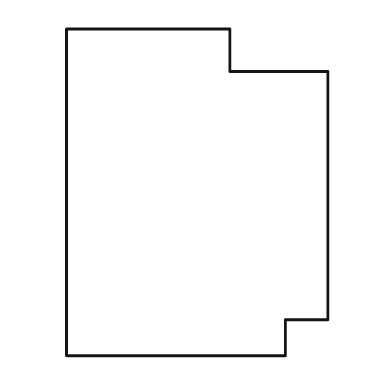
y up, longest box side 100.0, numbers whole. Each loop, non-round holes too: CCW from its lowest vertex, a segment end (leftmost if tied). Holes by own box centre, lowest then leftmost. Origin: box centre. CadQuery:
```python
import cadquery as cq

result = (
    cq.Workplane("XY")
    .moveTo(-40.0, -50.0)
    .lineTo(27.0, -50.0)
    .lineTo(27.0, -39.0)
    .lineTo(40.0, -39.0)
    .lineTo(40.0, 37.0)
    .lineTo(10.0, 37.0)
    .lineTo(10.0, 50.0)
    .lineTo(-40.0, 50.0)
    .close()
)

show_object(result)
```